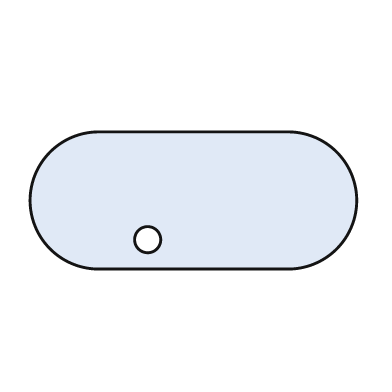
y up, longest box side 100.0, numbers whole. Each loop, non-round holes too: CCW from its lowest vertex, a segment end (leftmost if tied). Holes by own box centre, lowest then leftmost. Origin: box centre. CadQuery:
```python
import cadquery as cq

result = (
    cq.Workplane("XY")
    .moveTo(-29.0, -21.0)
    .lineTo(29.0, -21.0)
    .threePointArc((50.0, 0.0), (29.0, 21.0))
    .lineTo(-29.0, 21.0)
    .threePointArc((-50.0, 0.0), (-29.0, -21.0))
    .close()
    .moveTo(-14.0, -12.0)
    .circle(4.0)
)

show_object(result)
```